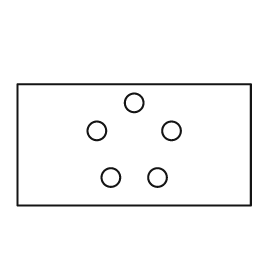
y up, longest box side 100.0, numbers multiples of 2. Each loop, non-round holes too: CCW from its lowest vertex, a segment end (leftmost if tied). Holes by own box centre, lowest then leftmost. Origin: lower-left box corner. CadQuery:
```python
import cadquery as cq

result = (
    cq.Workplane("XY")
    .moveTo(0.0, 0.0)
    .lineTo(100.0, 0.0)
    .lineTo(100.0, 52.0)
    .lineTo(0.0, 52.0)
    .close()
    .moveTo(40.0, 12.0)
    .circle(4.0)
    .moveTo(60.0, 12.0)
    .circle(4.0)
    .moveTo(34.0, 32.0)
    .circle(4.0)
    .moveTo(66.0, 32.0)
    .circle(4.0)
    .moveTo(50.0, 44.0)
    .circle(4.0)
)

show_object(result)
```